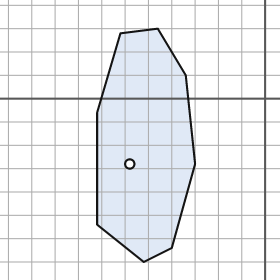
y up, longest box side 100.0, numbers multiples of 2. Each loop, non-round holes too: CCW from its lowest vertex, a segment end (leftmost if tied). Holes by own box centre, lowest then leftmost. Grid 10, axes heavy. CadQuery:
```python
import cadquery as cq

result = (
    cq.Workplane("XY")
    .moveTo(-52.0, -70.0)
    .lineTo(-40.0, -64.0)
    .lineTo(-30.0, -28.0)
    .lineTo(-34.0, 10.0)
    .lineTo(-46.0, 30.0)
    .lineTo(-62.0, 28.0)
    .lineTo(-72.0, -6.0)
    .lineTo(-72.0, -54.0)
    .close()
    .moveTo(-58.0, -28.0)
    .circle(2.0)
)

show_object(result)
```